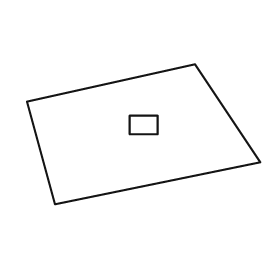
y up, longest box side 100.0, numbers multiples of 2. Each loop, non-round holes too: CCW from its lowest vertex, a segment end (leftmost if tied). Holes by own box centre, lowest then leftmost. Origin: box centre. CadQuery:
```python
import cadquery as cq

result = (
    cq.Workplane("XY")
    .moveTo(-38.0, -30.0)
    .lineTo(50.0, -12.0)
    .lineTo(22.0, 30.0)
    .lineTo(-50.0, 14.0)
    .close()
    .moveTo(-6.0, 0.0)
    .lineTo(6.0, 0.0)
    .lineTo(6.0, 8.0)
    .lineTo(-6.0, 8.0)
    .close()
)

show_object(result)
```